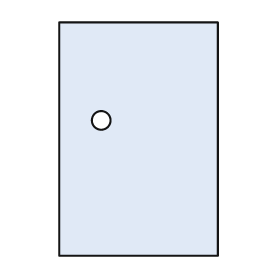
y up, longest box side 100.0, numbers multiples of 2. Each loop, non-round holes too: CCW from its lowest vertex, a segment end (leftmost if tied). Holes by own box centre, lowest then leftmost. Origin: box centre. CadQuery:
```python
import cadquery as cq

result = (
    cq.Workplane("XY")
    .moveTo(-34.0, -50.0)
    .lineTo(34.0, -50.0)
    .lineTo(34.0, 50.0)
    .lineTo(-34.0, 50.0)
    .close()
    .moveTo(-16.0, 8.0)
    .circle(4.0)
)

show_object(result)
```